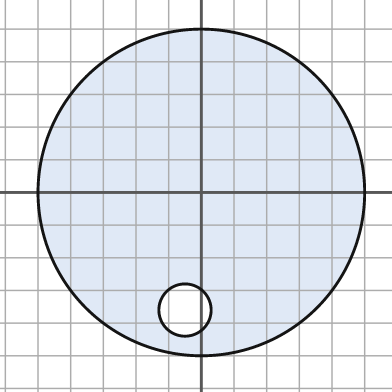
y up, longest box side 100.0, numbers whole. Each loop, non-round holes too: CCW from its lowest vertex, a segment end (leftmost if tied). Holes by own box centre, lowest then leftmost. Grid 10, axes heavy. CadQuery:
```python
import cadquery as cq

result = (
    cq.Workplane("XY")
    .moveTo(0.0, 0.0)
    .circle(50.0)
    .moveTo(-5.0, -36.0)
    .circle(8.0)
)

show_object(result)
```